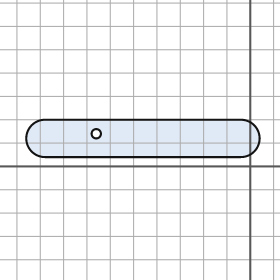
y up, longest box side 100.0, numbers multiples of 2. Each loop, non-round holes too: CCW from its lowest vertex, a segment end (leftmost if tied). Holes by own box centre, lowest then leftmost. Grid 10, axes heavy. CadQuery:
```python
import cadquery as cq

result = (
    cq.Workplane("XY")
    .moveTo(-88.0, 4.0)
    .lineTo(-4.0, 4.0)
    .threePointArc((4.0, 12.0), (-4.0, 20.0))
    .lineTo(-88.0, 20.0)
    .threePointArc((-96.0, 12.0), (-88.0, 4.0))
    .close()
    .moveTo(-66.0, 14.0)
    .circle(2.0)
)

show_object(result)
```